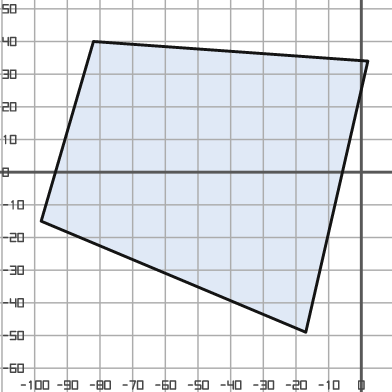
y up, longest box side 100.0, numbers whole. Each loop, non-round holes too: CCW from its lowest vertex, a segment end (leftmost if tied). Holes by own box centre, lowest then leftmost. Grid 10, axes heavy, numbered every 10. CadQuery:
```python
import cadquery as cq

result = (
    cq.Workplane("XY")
    .moveTo(-17.0, -49.0)
    .lineTo(2.0, 34.0)
    .lineTo(-82.0, 40.0)
    .lineTo(-98.0, -15.0)
    .close()
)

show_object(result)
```